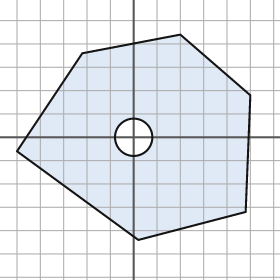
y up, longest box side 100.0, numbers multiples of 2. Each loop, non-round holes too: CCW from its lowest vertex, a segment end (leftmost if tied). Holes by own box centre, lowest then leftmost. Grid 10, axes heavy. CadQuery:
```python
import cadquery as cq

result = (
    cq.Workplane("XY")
    .moveTo(2.0, -44.0)
    .lineTo(48.0, -32.0)
    .lineTo(50.0, 18.0)
    .lineTo(20.0, 44.0)
    .lineTo(-22.0, 36.0)
    .lineTo(-50.0, -6.0)
    .close()
    .moveTo(0.0, 0.0)
    .circle(8.0)
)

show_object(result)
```